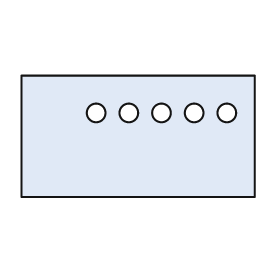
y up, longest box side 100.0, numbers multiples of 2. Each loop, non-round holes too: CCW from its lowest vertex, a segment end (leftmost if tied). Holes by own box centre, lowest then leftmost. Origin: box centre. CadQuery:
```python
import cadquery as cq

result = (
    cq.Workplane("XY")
    .moveTo(-50.0, -26.0)
    .lineTo(50.0, -26.0)
    .lineTo(50.0, 26.0)
    .lineTo(-50.0, 26.0)
    .close()
    .moveTo(-18.0, 10.0)
    .circle(4.0)
    .moveTo(-4.0, 10.0)
    .circle(4.0)
    .moveTo(10.0, 10.0)
    .circle(4.0)
    .moveTo(24.0, 10.0)
    .circle(4.0)
    .moveTo(38.0, 10.0)
    .circle(4.0)
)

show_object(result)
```